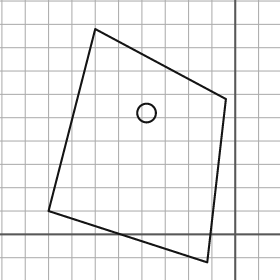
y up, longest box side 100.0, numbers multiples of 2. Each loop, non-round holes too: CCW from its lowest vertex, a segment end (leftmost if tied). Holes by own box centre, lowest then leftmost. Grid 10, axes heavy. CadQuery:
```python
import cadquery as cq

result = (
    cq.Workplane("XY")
    .moveTo(-12.0, -12.0)
    .lineTo(-4.0, 58.0)
    .lineTo(-60.0, 88.0)
    .lineTo(-80.0, 10.0)
    .close()
    .moveTo(-38.0, 52.0)
    .circle(4.0)
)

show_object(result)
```